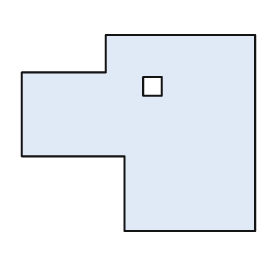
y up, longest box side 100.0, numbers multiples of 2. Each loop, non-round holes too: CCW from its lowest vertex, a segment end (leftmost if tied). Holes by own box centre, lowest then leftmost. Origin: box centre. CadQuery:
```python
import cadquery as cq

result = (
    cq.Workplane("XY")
    .moveTo(-6.0, -42.0)
    .lineTo(50.0, -42.0)
    .lineTo(50.0, 42.0)
    .lineTo(-14.0, 42.0)
    .lineTo(-14.0, 26.0)
    .lineTo(-50.0, 26.0)
    .lineTo(-50.0, -10.0)
    .lineTo(-6.0, -10.0)
    .close()
    .moveTo(2.0, 16.0)
    .lineTo(10.0, 16.0)
    .lineTo(10.0, 24.0)
    .lineTo(2.0, 24.0)
    .close()
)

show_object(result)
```